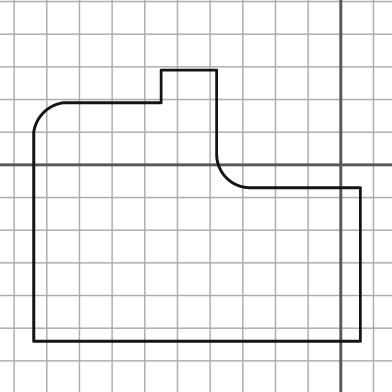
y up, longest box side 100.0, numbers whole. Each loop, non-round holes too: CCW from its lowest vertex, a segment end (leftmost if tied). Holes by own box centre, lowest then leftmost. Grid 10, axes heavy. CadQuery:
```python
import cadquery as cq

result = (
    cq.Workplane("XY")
    .moveTo(-94.0, -54.0)
    .lineTo(6.0, -54.0)
    .lineTo(6.0, -7.0)
    .lineTo(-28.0, -7.0)
    .threePointArc((-35.0, -4.0), (-38.0, 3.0))
    .lineTo(-38.0, 29.0)
    .lineTo(-55.0, 29.0)
    .lineTo(-55.0, 19.0)
    .lineTo(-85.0, 19.0)
    .threePointArc((-91.0, 16.0), (-94.0, 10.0))
    .close()
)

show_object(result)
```